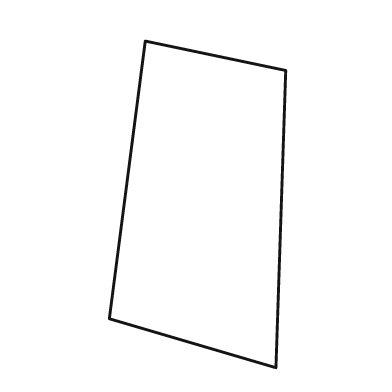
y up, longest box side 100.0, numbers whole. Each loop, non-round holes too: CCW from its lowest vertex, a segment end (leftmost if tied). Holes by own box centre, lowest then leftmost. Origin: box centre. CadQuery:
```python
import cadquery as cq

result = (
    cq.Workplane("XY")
    .moveTo(24.0, -50.0)
    .lineTo(27.0, 41.0)
    .lineTo(-16.0, 50.0)
    .lineTo(-27.0, -35.0)
    .close()
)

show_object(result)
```